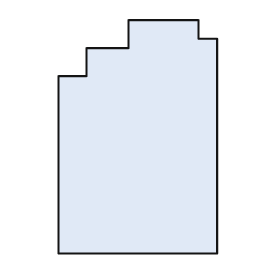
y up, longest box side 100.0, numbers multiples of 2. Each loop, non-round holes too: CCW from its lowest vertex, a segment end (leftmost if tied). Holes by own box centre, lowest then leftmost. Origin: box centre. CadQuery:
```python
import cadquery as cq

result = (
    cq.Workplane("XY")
    .moveTo(-34.0, -50.0)
    .lineTo(34.0, -50.0)
    .lineTo(34.0, 42.0)
    .lineTo(26.0, 42.0)
    .lineTo(26.0, 50.0)
    .lineTo(-4.0, 50.0)
    .lineTo(-4.0, 38.0)
    .lineTo(-22.0, 38.0)
    .lineTo(-22.0, 26.0)
    .lineTo(-34.0, 26.0)
    .close()
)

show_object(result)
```